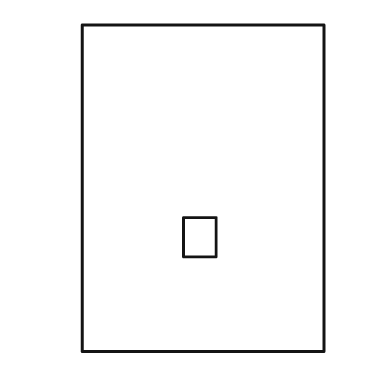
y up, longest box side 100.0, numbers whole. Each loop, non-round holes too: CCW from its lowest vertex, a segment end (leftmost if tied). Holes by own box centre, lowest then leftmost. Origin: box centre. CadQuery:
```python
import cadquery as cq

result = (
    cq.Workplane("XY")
    .moveTo(-37.0, -50.0)
    .lineTo(37.0, -50.0)
    .lineTo(37.0, 50.0)
    .lineTo(-37.0, 50.0)
    .close()
    .moveTo(-6.0, -21.0)
    .lineTo(4.0, -21.0)
    .lineTo(4.0, -9.0)
    .lineTo(-6.0, -9.0)
    .close()
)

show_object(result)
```